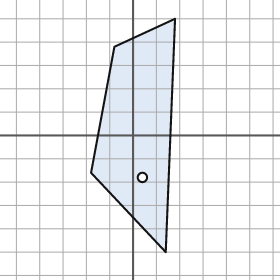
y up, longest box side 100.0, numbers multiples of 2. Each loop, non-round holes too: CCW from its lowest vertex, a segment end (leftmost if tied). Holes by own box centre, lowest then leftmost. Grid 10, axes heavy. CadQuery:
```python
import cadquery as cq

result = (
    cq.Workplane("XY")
    .moveTo(14.0, -50.0)
    .lineTo(18.0, 50.0)
    .lineTo(-8.0, 38.0)
    .lineTo(-18.0, -16.0)
    .close()
    .moveTo(4.0, -18.0)
    .circle(2.0)
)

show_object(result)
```